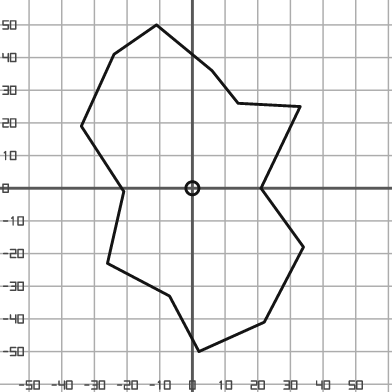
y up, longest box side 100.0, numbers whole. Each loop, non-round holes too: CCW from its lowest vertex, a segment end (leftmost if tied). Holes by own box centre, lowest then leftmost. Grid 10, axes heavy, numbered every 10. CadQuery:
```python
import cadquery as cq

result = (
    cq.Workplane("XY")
    .moveTo(2.0, -50.0)
    .lineTo(22.0, -41.0)
    .lineTo(34.0, -18.0)
    .lineTo(21.0, 0.0)
    .lineTo(33.0, 25.0)
    .lineTo(14.0, 26.0)
    .lineTo(6.0, 36.0)
    .lineTo(-11.0, 50.0)
    .lineTo(-24.0, 41.0)
    .lineTo(-34.0, 19.0)
    .lineTo(-21.0, -1.0)
    .lineTo(-26.0, -23.0)
    .lineTo(-7.0, -33.0)
    .close()
    .moveTo(0.0, 0.0)
    .circle(2.0)
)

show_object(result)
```